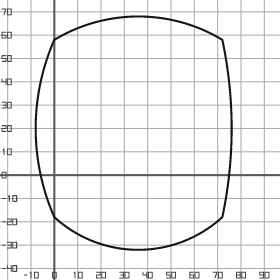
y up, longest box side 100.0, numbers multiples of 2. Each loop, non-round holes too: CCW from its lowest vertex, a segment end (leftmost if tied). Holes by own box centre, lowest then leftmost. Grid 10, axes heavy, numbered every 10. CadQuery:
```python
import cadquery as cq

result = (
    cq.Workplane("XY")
    .moveTo(0.0, -18.0)
    .threePointArc((36.0, -32.0), (72.0, -18.0))
    .threePointArc((76.0, 20.0), (72.0, 58.0))
    .threePointArc((36.0, 68.0), (0.0, 58.0))
    .threePointArc((-8.0, 20.0), (0.0, -18.0))
    .close()
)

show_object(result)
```